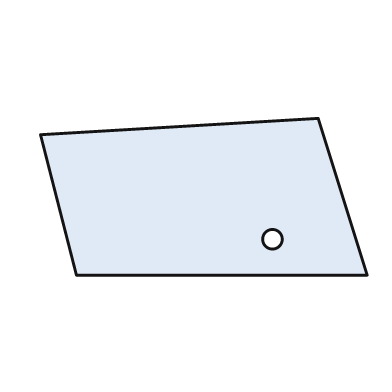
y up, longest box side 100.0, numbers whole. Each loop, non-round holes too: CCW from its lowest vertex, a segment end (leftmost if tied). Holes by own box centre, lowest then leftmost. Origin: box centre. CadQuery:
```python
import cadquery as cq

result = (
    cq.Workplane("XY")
    .moveTo(-39.0, -24.0)
    .lineTo(50.0, -24.0)
    .lineTo(35.0, 24.0)
    .lineTo(-50.0, 19.0)
    .close()
    .moveTo(21.0, -13.0)
    .circle(3.0)
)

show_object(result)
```